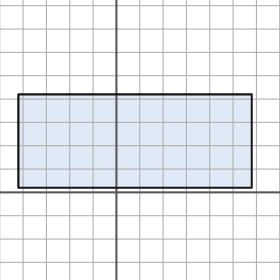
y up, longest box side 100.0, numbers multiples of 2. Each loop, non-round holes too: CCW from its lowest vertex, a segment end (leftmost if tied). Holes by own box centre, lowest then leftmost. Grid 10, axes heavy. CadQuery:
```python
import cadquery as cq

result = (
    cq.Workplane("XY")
    .moveTo(-42.0, 2.0)
    .lineTo(58.0, 2.0)
    .lineTo(58.0, 42.0)
    .lineTo(-42.0, 42.0)
    .close()
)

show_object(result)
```